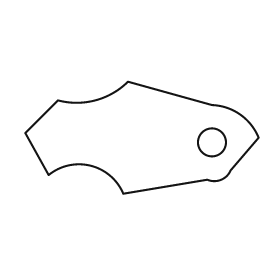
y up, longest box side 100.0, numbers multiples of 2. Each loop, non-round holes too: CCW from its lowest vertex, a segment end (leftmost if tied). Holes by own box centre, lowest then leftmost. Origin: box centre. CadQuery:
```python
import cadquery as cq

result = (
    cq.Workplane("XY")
    .moveTo(-8.0, -24.0)
    .lineTo(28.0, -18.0)
    .threePointArc((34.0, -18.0), (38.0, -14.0))
    .lineTo(50.0, 0.0)
    .threePointArc((42.0, 10.0), (30.0, 14.0))
    .lineTo(-6.0, 24.0)
    .threePointArc((-20.0, 16.0), (-36.0, 16.0))
    .lineTo(-50.0, 2.0)
    .lineTo(-40.0, -16.0)
    .threePointArc((-22.0, -12.0), (-8.0, -24.0))
    .close()
    .moveTo(30.0, -2.0)
    .circle(6.0)
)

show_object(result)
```